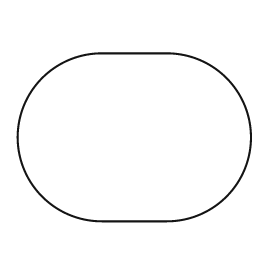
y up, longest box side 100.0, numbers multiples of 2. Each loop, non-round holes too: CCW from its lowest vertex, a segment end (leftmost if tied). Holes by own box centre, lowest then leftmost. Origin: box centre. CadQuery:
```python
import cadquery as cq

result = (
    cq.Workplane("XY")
    .moveTo(-14.0, -36.0)
    .lineTo(14.0, -36.0)
    .threePointArc((50.0, 0.0), (14.0, 36.0))
    .lineTo(-14.0, 36.0)
    .threePointArc((-50.0, 0.0), (-14.0, -36.0))
    .close()
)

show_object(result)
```